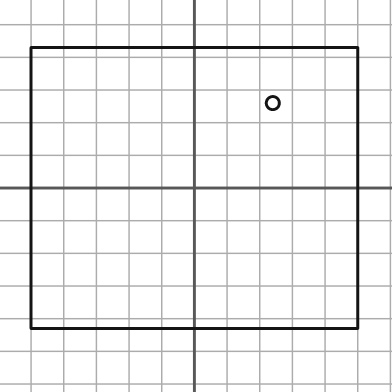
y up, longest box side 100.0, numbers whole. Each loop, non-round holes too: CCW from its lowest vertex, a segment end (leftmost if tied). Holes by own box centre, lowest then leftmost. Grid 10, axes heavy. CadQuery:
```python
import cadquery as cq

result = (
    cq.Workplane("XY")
    .moveTo(-50.0, -43.0)
    .lineTo(50.0, -43.0)
    .lineTo(50.0, 43.0)
    .lineTo(-50.0, 43.0)
    .close()
    .moveTo(24.0, 26.0)
    .circle(2.0)
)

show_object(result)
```